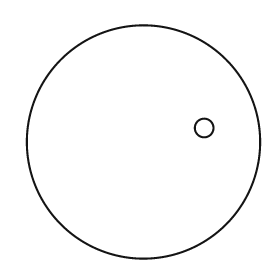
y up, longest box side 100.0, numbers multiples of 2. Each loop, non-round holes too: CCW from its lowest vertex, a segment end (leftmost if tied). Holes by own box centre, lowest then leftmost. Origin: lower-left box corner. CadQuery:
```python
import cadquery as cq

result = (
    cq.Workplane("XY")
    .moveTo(50.0, 50.0)
    .circle(50.0)
    .moveTo(76.0, 56.0)
    .circle(4.0)
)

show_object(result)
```